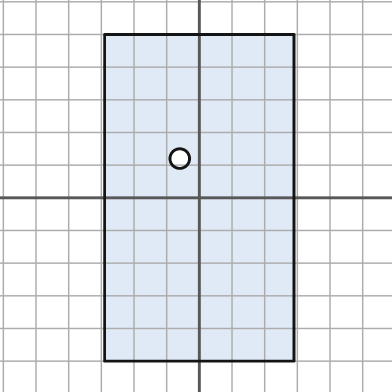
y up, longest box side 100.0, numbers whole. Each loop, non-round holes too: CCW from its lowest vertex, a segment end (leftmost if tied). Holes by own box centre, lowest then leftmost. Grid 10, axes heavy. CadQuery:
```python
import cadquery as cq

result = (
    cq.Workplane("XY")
    .moveTo(-29.0, -50.0)
    .lineTo(29.0, -50.0)
    .lineTo(29.0, 50.0)
    .lineTo(-29.0, 50.0)
    .close()
    .moveTo(-6.0, 12.0)
    .circle(3.0)
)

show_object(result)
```